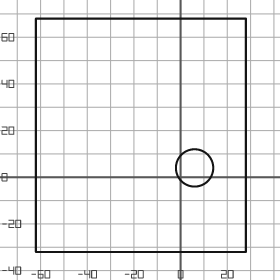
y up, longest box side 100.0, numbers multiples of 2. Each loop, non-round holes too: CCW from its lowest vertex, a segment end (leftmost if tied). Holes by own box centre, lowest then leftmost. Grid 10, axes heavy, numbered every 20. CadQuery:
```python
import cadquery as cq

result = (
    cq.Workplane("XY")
    .moveTo(-62.0, -32.0)
    .lineTo(28.0, -32.0)
    .lineTo(28.0, 68.0)
    .lineTo(-62.0, 68.0)
    .close()
    .moveTo(6.0, 4.0)
    .circle(8.0)
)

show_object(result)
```